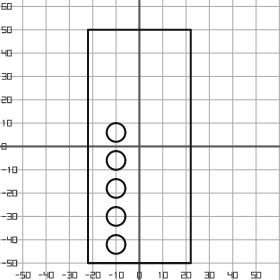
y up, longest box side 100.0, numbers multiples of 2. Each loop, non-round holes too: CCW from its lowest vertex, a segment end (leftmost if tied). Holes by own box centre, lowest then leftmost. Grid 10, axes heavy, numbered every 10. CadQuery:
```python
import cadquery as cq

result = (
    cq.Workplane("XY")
    .moveTo(-22.0, -50.0)
    .lineTo(22.0, -50.0)
    .lineTo(22.0, 50.0)
    .lineTo(-22.0, 50.0)
    .close()
    .moveTo(-10.0, -42.0)
    .circle(4.0)
    .moveTo(-10.0, -30.0)
    .circle(4.0)
    .moveTo(-10.0, -18.0)
    .circle(4.0)
    .moveTo(-10.0, -6.0)
    .circle(4.0)
    .moveTo(-10.0, 6.0)
    .circle(4.0)
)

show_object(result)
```